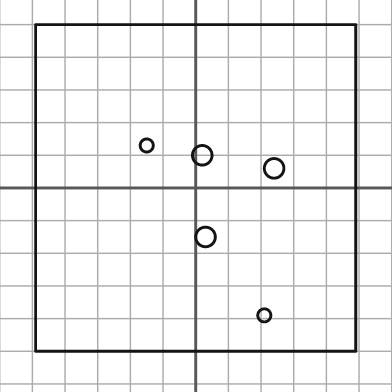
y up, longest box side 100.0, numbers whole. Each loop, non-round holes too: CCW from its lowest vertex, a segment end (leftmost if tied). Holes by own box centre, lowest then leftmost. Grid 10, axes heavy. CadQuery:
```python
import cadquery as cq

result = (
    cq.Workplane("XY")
    .moveTo(-49.0, -50.0)
    .lineTo(49.0, -50.0)
    .lineTo(49.0, 50.0)
    .lineTo(-49.0, 50.0)
    .close()
    .moveTo(21.0, -39.0)
    .circle(2.0)
    .moveTo(3.0, -15.0)
    .circle(3.0)
    .moveTo(24.0, 6.0)
    .circle(3.0)
    .moveTo(2.0, 10.0)
    .circle(3.0)
    .moveTo(-15.0, 13.0)
    .circle(2.0)
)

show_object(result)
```